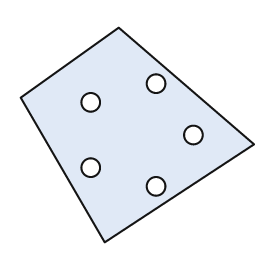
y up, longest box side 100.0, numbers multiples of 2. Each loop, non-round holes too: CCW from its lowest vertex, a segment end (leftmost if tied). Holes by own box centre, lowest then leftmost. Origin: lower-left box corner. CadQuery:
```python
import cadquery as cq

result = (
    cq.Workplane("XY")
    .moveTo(36.0, 0.0)
    .lineTo(100.0, 42.0)
    .lineTo(42.0, 92.0)
    .lineTo(0.0, 62.0)
    .close()
    .moveTo(58.0, 24.0)
    .circle(4.0)
    .moveTo(30.0, 32.0)
    .circle(4.0)
    .moveTo(74.0, 46.0)
    .circle(4.0)
    .moveTo(30.0, 60.0)
    .circle(4.0)
    .moveTo(58.0, 68.0)
    .circle(4.0)
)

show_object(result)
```